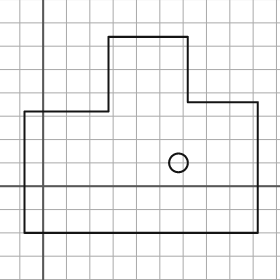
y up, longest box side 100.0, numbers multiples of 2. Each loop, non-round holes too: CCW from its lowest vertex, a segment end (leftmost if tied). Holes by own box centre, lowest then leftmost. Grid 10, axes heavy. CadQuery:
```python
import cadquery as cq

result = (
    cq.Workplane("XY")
    .moveTo(-8.0, -20.0)
    .lineTo(92.0, -20.0)
    .lineTo(92.0, 36.0)
    .lineTo(62.0, 36.0)
    .lineTo(62.0, 64.0)
    .lineTo(28.0, 64.0)
    .lineTo(28.0, 32.0)
    .lineTo(-8.0, 32.0)
    .close()
    .moveTo(58.0, 10.0)
    .circle(4.0)
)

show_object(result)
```